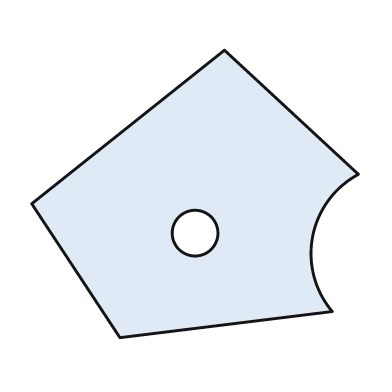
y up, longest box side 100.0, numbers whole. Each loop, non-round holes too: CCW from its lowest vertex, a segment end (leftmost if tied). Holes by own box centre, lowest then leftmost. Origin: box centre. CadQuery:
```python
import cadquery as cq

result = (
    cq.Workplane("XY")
    .moveTo(-23.0, -44.0)
    .lineTo(42.0, -36.0)
    .threePointArc((36.0, -13.0), (50.0, 6.0))
    .lineTo(9.0, 44.0)
    .lineTo(-50.0, -3.0)
    .close()
    .moveTo(0.0, -12.0)
    .circle(7.0)
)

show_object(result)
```